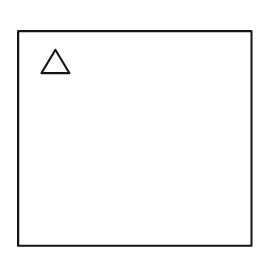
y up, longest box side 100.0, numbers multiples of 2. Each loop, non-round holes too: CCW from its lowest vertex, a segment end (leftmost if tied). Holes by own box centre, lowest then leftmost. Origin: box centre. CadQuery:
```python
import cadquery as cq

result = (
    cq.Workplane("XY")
    .moveTo(-50.0, -46.0)
    .lineTo(50.0, -46.0)
    .lineTo(50.0, 46.0)
    .lineTo(-50.0, 46.0)
    .close()
    .moveTo(-40.0, 28.0)
    .lineTo(-28.0, 28.0)
    .lineTo(-34.0, 38.0)
    .close()
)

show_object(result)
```